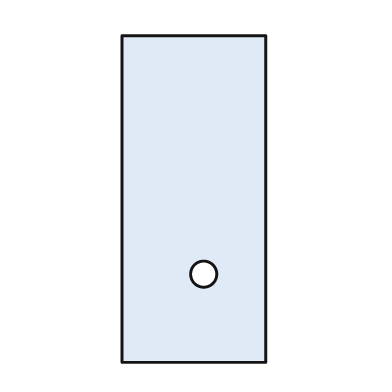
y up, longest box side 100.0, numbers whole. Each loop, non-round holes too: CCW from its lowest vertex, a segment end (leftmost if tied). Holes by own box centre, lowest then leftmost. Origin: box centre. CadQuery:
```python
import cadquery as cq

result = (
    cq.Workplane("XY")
    .moveTo(-22.0, -50.0)
    .lineTo(22.0, -50.0)
    .lineTo(22.0, 50.0)
    .lineTo(-22.0, 50.0)
    .close()
    .moveTo(3.0, -23.0)
    .circle(4.0)
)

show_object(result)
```